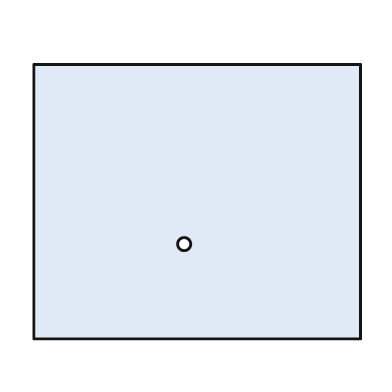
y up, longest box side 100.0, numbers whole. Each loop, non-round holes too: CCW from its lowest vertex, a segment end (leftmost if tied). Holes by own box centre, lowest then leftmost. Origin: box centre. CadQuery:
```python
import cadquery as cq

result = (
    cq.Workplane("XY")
    .moveTo(-50.0, -42.0)
    .lineTo(50.0, -42.0)
    .lineTo(50.0, 42.0)
    .lineTo(-50.0, 42.0)
    .close()
    .moveTo(-4.0, -13.0)
    .circle(2.0)
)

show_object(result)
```